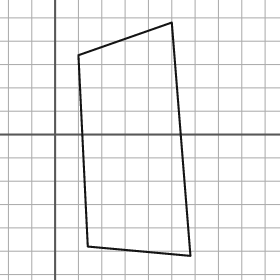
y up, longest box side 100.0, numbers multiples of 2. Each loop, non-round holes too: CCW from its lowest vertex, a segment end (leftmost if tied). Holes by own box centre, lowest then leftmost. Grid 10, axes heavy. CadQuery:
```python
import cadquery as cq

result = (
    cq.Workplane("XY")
    .moveTo(58.0, -52.0)
    .lineTo(50.0, 48.0)
    .lineTo(10.0, 34.0)
    .lineTo(14.0, -48.0)
    .close()
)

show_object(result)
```